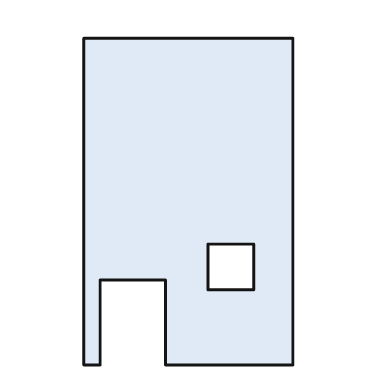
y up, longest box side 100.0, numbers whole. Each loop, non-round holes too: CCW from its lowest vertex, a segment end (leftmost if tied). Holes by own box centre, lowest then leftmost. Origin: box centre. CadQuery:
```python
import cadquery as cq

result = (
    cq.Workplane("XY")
    .moveTo(-32.0, -50.0)
    .lineTo(-27.0, -50.0)
    .lineTo(-27.0, -24.0)
    .lineTo(-7.0, -24.0)
    .lineTo(-7.0, -50.0)
    .lineTo(32.0, -50.0)
    .lineTo(32.0, 50.0)
    .lineTo(-32.0, 50.0)
    .close()
    .moveTo(6.0, -27.0)
    .lineTo(20.0, -27.0)
    .lineTo(20.0, -13.0)
    .lineTo(6.0, -13.0)
    .close()
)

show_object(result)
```